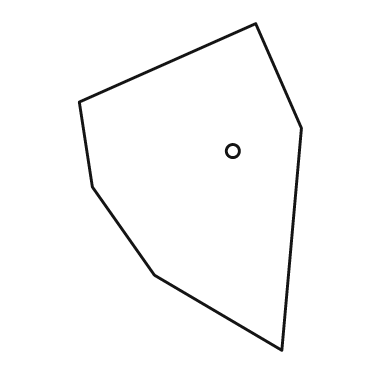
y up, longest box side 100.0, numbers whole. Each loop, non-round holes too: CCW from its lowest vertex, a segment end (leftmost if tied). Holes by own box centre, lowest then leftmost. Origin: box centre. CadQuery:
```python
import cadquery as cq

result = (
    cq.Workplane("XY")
    .moveTo(28.0, -50.0)
    .lineTo(34.0, 18.0)
    .lineTo(20.0, 50.0)
    .lineTo(-34.0, 26.0)
    .lineTo(-30.0, 0.0)
    .lineTo(-11.0, -27.0)
    .close()
    .moveTo(13.0, 11.0)
    .circle(2.0)
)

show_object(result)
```